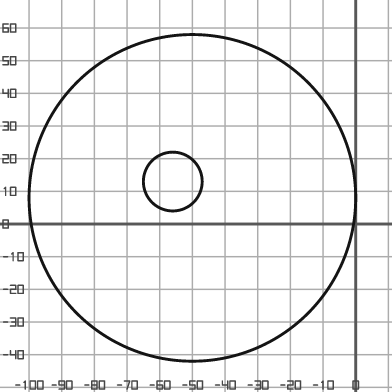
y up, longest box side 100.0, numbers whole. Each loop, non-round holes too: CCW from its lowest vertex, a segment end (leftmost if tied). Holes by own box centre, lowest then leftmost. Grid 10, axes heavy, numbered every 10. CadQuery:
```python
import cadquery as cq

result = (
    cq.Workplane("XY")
    .moveTo(-50.0, 8.0)
    .circle(50.0)
    .moveTo(-56.0, 13.0)
    .circle(9.0)
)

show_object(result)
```